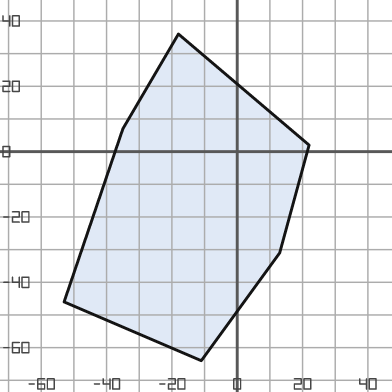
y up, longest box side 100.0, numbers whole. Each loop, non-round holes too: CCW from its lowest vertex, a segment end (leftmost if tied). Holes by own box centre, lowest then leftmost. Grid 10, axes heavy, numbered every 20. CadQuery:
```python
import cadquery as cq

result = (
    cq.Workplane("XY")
    .moveTo(-11.0, -64.0)
    .lineTo(13.0, -31.0)
    .lineTo(22.0, 2.0)
    .lineTo(-18.0, 36.0)
    .lineTo(-35.0, 7.0)
    .lineTo(-53.0, -46.0)
    .close()
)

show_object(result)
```